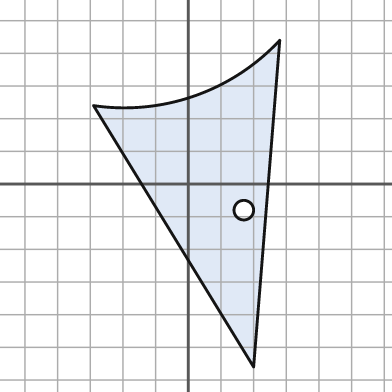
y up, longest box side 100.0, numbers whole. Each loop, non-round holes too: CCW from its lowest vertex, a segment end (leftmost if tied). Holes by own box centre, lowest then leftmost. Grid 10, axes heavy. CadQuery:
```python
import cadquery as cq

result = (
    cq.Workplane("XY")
    .moveTo(20.0, -56.0)
    .lineTo(28.0, 44.0)
    .threePointArc((2.0, 27.0), (-29.0, 24.0))
    .close()
    .moveTo(17.0, -8.0)
    .circle(3.0)
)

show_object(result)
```